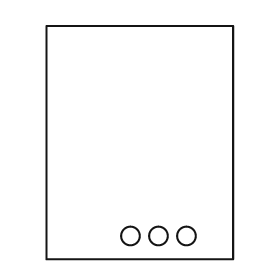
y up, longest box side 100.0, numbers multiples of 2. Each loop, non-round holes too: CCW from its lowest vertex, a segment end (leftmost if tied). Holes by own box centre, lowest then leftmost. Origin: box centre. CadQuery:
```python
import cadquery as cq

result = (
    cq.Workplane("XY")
    .moveTo(-40.0, -50.0)
    .lineTo(40.0, -50.0)
    .lineTo(40.0, 50.0)
    .lineTo(-40.0, 50.0)
    .close()
    .moveTo(-4.0, -40.0)
    .circle(4.0)
    .moveTo(8.0, -40.0)
    .circle(4.0)
    .moveTo(20.0, -40.0)
    .circle(4.0)
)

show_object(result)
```